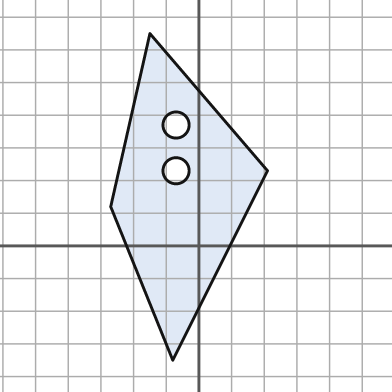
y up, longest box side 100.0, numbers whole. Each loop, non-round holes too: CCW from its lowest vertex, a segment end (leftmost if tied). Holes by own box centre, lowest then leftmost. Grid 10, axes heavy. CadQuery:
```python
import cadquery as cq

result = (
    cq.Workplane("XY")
    .moveTo(-8.0, -35.0)
    .lineTo(21.0, 23.0)
    .lineTo(-15.0, 65.0)
    .lineTo(-27.0, 12.0)
    .close()
    .moveTo(-7.0, 23.0)
    .circle(4.0)
    .moveTo(-7.0, 37.0)
    .circle(4.0)
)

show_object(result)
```